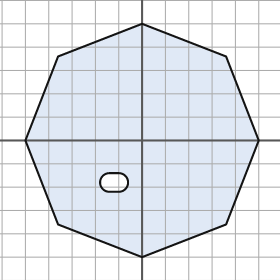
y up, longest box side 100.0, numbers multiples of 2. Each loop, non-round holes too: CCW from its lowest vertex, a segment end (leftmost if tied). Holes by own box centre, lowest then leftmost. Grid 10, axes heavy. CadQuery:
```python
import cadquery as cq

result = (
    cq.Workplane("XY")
    .moveTo(0.0, -50.0)
    .lineTo(36.0, -36.0)
    .lineTo(50.0, 0.0)
    .lineTo(36.0, 36.0)
    .lineTo(0.0, 50.0)
    .lineTo(-36.0, 36.0)
    .lineTo(-50.0, 0.0)
    .lineTo(-36.0, -36.0)
    .close()
    .moveTo(-14.0, -22.0)
    .lineTo(-10.0, -22.0)
    .threePointArc((-6.0, -18.0), (-10.0, -14.0))
    .lineTo(-14.0, -14.0)
    .threePointArc((-18.0, -18.0), (-14.0, -22.0))
    .close()
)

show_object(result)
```